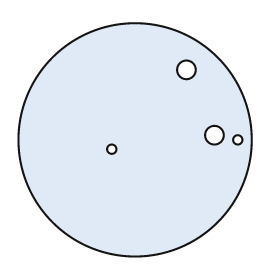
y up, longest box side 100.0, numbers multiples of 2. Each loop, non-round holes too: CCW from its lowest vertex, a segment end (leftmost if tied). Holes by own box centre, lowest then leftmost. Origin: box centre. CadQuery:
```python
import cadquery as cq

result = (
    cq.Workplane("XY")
    .moveTo(0.0, 0.0)
    .circle(50.0)
    .moveTo(-10.0, -4.0)
    .circle(2.0)
    .moveTo(44.0, 0.0)
    .circle(2.0)
    .moveTo(34.0, 2.0)
    .circle(4.0)
    .moveTo(22.0, 30.0)
    .circle(4.0)
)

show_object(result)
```